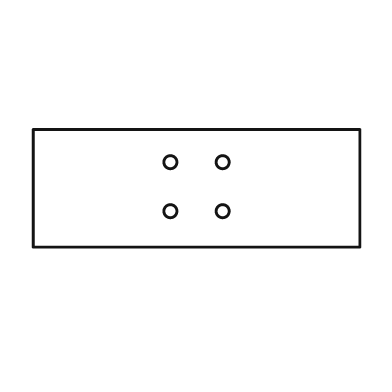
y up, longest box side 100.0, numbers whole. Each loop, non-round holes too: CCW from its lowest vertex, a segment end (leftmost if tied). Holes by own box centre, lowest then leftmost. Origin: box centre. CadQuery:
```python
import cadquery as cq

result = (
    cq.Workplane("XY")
    .moveTo(-50.0, -18.0)
    .lineTo(50.0, -18.0)
    .lineTo(50.0, 18.0)
    .lineTo(-50.0, 18.0)
    .close()
    .moveTo(-8.0, -7.0)
    .circle(2.0)
    .moveTo(8.0, -7.0)
    .circle(2.0)
    .moveTo(-8.0, 8.0)
    .circle(2.0)
    .moveTo(8.0, 8.0)
    .circle(2.0)
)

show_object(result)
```